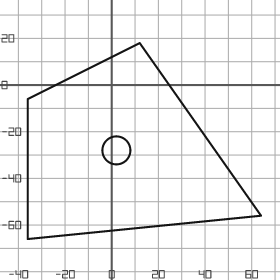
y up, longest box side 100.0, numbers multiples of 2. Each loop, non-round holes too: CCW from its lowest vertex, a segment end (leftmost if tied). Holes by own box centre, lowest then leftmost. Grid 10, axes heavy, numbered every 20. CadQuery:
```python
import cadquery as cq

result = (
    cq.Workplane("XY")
    .moveTo(-36.0, -66.0)
    .lineTo(64.0, -56.0)
    .lineTo(12.0, 18.0)
    .lineTo(-36.0, -6.0)
    .close()
    .moveTo(2.0, -28.0)
    .circle(6.0)
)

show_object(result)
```